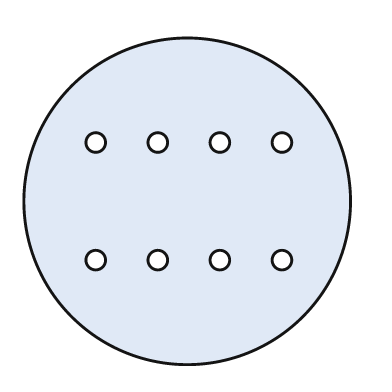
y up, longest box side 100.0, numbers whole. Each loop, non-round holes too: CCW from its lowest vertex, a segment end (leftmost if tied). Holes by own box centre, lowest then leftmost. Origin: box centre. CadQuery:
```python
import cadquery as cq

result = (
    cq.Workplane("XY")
    .moveTo(0.0, 0.0)
    .circle(50.0)
    .moveTo(-28.0, -18.0)
    .circle(3.0)
    .moveTo(-9.0, -18.0)
    .circle(3.0)
    .moveTo(10.0, -18.0)
    .circle(3.0)
    .moveTo(29.0, -18.0)
    .circle(3.0)
    .moveTo(-28.0, 18.0)
    .circle(3.0)
    .moveTo(-9.0, 18.0)
    .circle(3.0)
    .moveTo(10.0, 18.0)
    .circle(3.0)
    .moveTo(29.0, 18.0)
    .circle(3.0)
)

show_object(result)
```